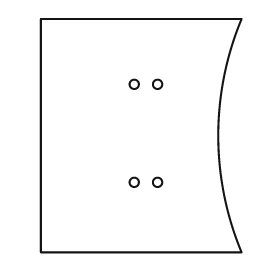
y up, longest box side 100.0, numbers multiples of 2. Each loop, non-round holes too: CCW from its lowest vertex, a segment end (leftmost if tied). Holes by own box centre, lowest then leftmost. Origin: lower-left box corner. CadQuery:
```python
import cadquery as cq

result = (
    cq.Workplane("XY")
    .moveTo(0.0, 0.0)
    .lineTo(86.0, 0.0)
    .threePointArc((76.0, 50.0), (86.0, 100.0))
    .lineTo(0.0, 100.0)
    .close()
    .moveTo(40.0, 30.0)
    .circle(2.0)
    .moveTo(50.0, 30.0)
    .circle(2.0)
    .moveTo(40.0, 72.0)
    .circle(2.0)
    .moveTo(50.0, 72.0)
    .circle(2.0)
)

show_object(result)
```